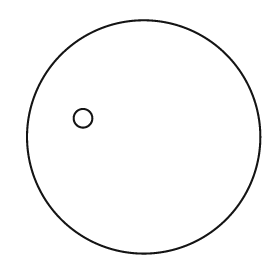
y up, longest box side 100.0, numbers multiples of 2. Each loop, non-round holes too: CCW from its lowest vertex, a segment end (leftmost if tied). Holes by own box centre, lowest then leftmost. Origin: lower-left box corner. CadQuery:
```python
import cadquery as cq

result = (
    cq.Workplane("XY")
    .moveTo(50.0, 50.0)
    .circle(50.0)
    .moveTo(24.0, 58.0)
    .circle(4.0)
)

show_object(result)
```